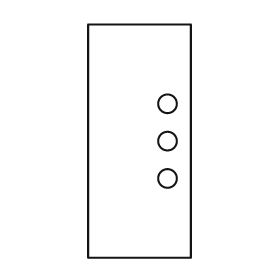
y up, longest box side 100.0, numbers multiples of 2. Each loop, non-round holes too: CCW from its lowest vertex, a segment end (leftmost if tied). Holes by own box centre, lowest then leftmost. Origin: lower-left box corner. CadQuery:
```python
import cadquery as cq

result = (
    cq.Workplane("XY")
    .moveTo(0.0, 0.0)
    .lineTo(44.0, 0.0)
    .lineTo(44.0, 100.0)
    .lineTo(0.0, 100.0)
    .close()
    .moveTo(34.0, 34.0)
    .circle(4.0)
    .moveTo(34.0, 50.0)
    .circle(4.0)
    .moveTo(34.0, 66.0)
    .circle(4.0)
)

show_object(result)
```